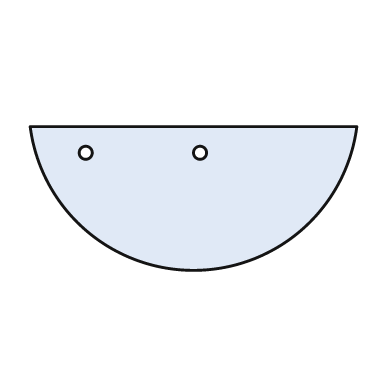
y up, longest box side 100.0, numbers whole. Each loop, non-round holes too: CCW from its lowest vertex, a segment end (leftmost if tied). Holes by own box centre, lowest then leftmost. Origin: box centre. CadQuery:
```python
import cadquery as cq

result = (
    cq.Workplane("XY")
    .moveTo(-50.0, 22.0)
    .threePointArc((0.0, -22.0), (50.0, 22.0))
    .close()
    .moveTo(-33.0, 14.0)
    .circle(2.0)
    .moveTo(2.0, 14.0)
    .circle(2.0)
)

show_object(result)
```